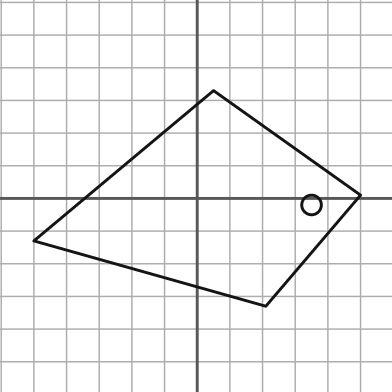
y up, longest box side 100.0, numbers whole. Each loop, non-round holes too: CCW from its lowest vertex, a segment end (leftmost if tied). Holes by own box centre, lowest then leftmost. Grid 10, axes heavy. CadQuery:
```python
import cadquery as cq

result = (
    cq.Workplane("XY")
    .moveTo(21.0, -33.0)
    .lineTo(50.0, 1.0)
    .lineTo(5.0, 33.0)
    .lineTo(-50.0, -13.0)
    .close()
    .moveTo(35.0, -2.0)
    .circle(3.0)
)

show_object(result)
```